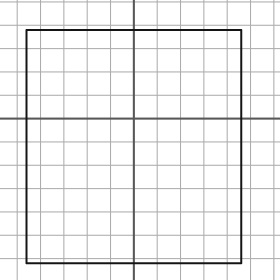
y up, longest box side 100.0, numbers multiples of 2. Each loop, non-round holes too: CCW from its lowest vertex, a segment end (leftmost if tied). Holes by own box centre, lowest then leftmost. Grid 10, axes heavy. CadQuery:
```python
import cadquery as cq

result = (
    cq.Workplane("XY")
    .moveTo(-46.0, -62.0)
    .lineTo(46.0, -62.0)
    .lineTo(46.0, 38.0)
    .lineTo(-46.0, 38.0)
    .close()
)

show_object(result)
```